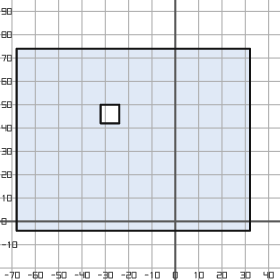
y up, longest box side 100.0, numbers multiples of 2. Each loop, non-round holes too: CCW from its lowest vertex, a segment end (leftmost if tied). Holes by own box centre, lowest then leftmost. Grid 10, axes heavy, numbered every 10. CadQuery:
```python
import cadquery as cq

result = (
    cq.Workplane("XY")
    .moveTo(-68.0, -4.0)
    .lineTo(32.0, -4.0)
    .lineTo(32.0, 74.0)
    .lineTo(-68.0, 74.0)
    .close()
    .moveTo(-32.0, 42.0)
    .lineTo(-24.0, 42.0)
    .lineTo(-24.0, 50.0)
    .lineTo(-32.0, 50.0)
    .close()
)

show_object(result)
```